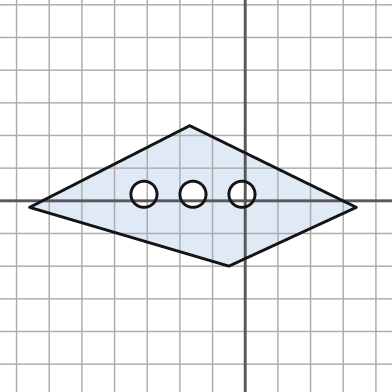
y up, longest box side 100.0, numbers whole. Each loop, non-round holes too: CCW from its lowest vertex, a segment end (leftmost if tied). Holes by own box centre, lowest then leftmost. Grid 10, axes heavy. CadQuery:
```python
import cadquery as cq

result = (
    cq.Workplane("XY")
    .moveTo(-5.0, -20.0)
    .lineTo(34.0, -2.0)
    .lineTo(-17.0, 23.0)
    .lineTo(-66.0, -2.0)
    .close()
    .moveTo(-31.0, 2.0)
    .circle(4.0)
    .moveTo(-16.0, 2.0)
    .circle(4.0)
    .moveTo(-1.0, 2.0)
    .circle(4.0)
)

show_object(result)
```